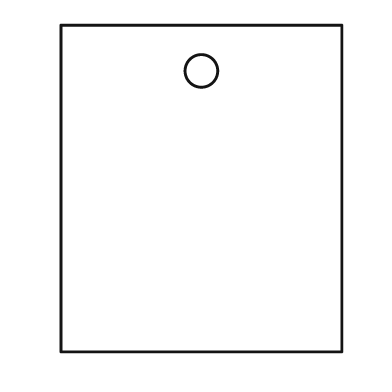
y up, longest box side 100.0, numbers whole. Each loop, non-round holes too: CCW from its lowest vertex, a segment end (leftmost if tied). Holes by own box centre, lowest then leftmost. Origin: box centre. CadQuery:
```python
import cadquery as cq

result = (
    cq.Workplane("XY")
    .moveTo(-43.0, -50.0)
    .lineTo(43.0, -50.0)
    .lineTo(43.0, 50.0)
    .lineTo(-43.0, 50.0)
    .close()
    .moveTo(0.0, 36.0)
    .circle(5.0)
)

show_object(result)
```